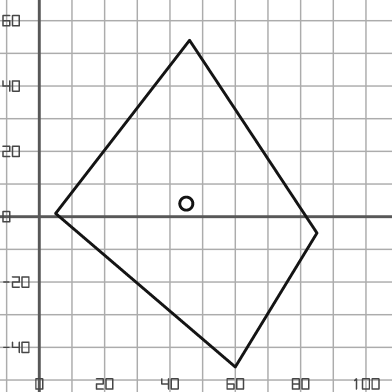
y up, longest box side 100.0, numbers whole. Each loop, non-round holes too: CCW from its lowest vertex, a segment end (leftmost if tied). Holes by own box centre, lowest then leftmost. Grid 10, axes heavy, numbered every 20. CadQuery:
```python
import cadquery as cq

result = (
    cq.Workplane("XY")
    .moveTo(60.0, -46.0)
    .lineTo(85.0, -5.0)
    .lineTo(46.0, 54.0)
    .lineTo(5.0, 1.0)
    .close()
    .moveTo(45.0, 4.0)
    .circle(2.0)
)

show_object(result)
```